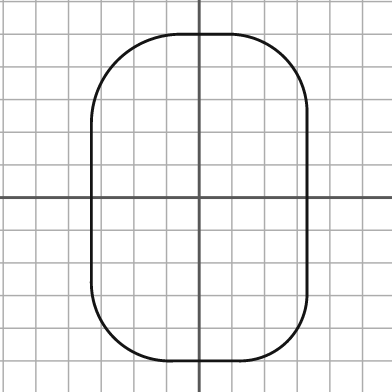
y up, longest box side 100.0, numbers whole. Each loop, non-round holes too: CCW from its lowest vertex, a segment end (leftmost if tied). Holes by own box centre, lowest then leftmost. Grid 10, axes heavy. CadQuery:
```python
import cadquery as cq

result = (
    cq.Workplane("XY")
    .moveTo(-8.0, -50.0)
    .lineTo(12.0, -50.0)
    .threePointArc((27.0, -44.0), (33.0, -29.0))
    .lineTo(33.0, 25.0)
    .threePointArc((26.0, 43.0), (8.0, 50.0))
    .lineTo(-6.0, 50.0)
    .threePointArc((-25.0, 42.0), (-33.0, 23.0))
    .lineTo(-33.0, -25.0)
    .threePointArc((-26.0, -43.0), (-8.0, -50.0))
    .close()
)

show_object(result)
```